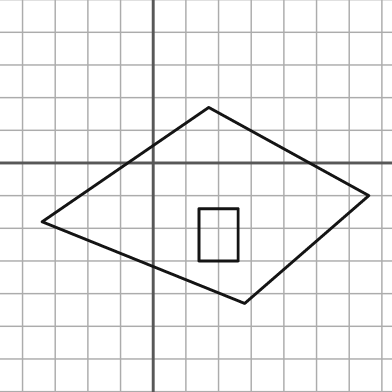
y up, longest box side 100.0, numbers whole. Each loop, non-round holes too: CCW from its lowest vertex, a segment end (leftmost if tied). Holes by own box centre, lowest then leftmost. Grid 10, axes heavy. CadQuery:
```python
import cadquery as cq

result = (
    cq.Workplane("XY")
    .moveTo(28.0, -43.0)
    .lineTo(66.0, -10.0)
    .lineTo(17.0, 17.0)
    .lineTo(-34.0, -18.0)
    .close()
    .moveTo(14.0, -30.0)
    .lineTo(26.0, -30.0)
    .lineTo(26.0, -14.0)
    .lineTo(14.0, -14.0)
    .close()
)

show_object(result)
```